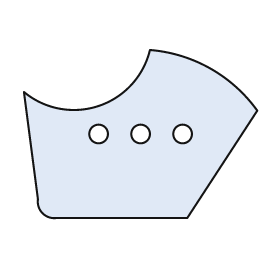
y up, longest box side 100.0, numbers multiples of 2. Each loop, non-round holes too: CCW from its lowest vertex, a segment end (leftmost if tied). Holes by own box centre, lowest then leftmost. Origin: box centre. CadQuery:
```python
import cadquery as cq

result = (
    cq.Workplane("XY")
    .moveTo(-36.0, -36.0)
    .lineTo(20.0, -36.0)
    .lineTo(50.0, 10.0)
    .threePointArc((30.0, 28.0), (4.0, 36.0))
    .threePointArc((-18.0, 12.0), (-50.0, 18.0))
    .lineTo(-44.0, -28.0)
    .threePointArc((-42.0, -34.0), (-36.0, -36.0))
    .close()
    .moveTo(-18.0, 0.0)
    .circle(4.0)
    .moveTo(0.0, 0.0)
    .circle(4.0)
    .moveTo(18.0, 0.0)
    .circle(4.0)
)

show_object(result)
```